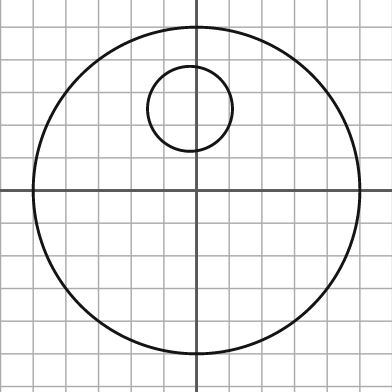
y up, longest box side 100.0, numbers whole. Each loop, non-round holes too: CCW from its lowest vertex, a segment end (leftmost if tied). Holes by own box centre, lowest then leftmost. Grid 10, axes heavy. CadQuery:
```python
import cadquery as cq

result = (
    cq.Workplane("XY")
    .moveTo(0.0, 0.0)
    .circle(50.0)
    .moveTo(-2.0, 25.0)
    .circle(13.0)
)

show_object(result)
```